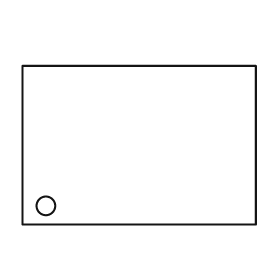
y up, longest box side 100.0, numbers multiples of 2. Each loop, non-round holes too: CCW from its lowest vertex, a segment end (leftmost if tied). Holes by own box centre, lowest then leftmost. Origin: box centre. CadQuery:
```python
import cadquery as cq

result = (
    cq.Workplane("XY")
    .moveTo(-50.0, -34.0)
    .lineTo(50.0, -34.0)
    .lineTo(50.0, 34.0)
    .lineTo(-50.0, 34.0)
    .close()
    .moveTo(-40.0, -26.0)
    .circle(4.0)
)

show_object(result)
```